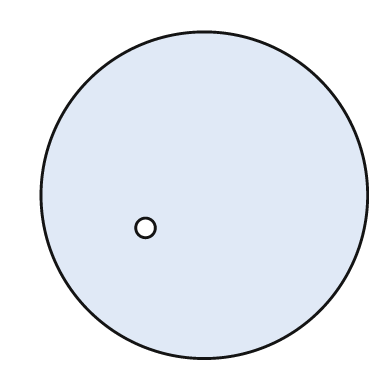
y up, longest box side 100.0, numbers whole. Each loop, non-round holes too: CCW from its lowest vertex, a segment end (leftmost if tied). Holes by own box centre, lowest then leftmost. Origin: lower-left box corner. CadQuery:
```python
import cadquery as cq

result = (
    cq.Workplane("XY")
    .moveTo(50.0, 50.0)
    .circle(50.0)
    .moveTo(32.0, 40.0)
    .circle(3.0)
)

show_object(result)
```